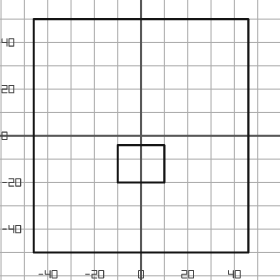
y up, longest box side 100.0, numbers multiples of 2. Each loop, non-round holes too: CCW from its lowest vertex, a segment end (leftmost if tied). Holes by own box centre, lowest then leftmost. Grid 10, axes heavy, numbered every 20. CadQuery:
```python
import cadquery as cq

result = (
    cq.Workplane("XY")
    .moveTo(-46.0, -50.0)
    .lineTo(46.0, -50.0)
    .lineTo(46.0, 50.0)
    .lineTo(-46.0, 50.0)
    .close()
    .moveTo(-10.0, -20.0)
    .lineTo(10.0, -20.0)
    .lineTo(10.0, -4.0)
    .lineTo(-10.0, -4.0)
    .close()
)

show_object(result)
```